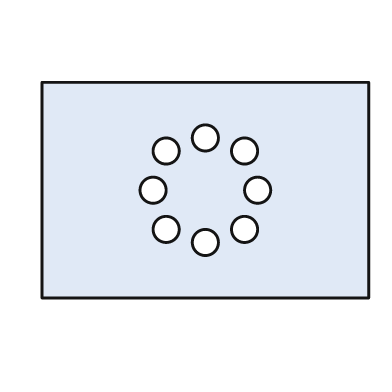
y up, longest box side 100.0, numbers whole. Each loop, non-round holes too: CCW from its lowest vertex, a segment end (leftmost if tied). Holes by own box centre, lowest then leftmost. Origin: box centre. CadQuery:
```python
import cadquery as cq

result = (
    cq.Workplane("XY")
    .moveTo(-50.0, -33.0)
    .lineTo(50.0, -33.0)
    .lineTo(50.0, 33.0)
    .lineTo(-50.0, 33.0)
    .close()
    .moveTo(0.0, -16.0)
    .circle(4.0)
    .moveTo(-12.0, -12.0)
    .circle(4.0)
    .moveTo(12.0, -12.0)
    .circle(4.0)
    .moveTo(-16.0, 0.0)
    .circle(4.0)
    .moveTo(16.0, 0.0)
    .circle(4.0)
    .moveTo(-12.0, 12.0)
    .circle(4.0)
    .moveTo(12.0, 12.0)
    .circle(4.0)
    .moveTo(0.0, 16.0)
    .circle(4.0)
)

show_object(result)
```